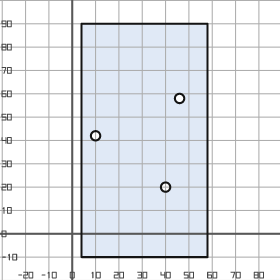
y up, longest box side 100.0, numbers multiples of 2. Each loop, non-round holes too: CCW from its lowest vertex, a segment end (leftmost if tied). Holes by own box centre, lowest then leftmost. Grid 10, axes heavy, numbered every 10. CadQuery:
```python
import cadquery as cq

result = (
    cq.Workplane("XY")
    .moveTo(4.0, -10.0)
    .lineTo(58.0, -10.0)
    .lineTo(58.0, 90.0)
    .lineTo(4.0, 90.0)
    .close()
    .moveTo(40.0, 20.0)
    .circle(2.0)
    .moveTo(10.0, 42.0)
    .circle(2.0)
    .moveTo(46.0, 58.0)
    .circle(2.0)
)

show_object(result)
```